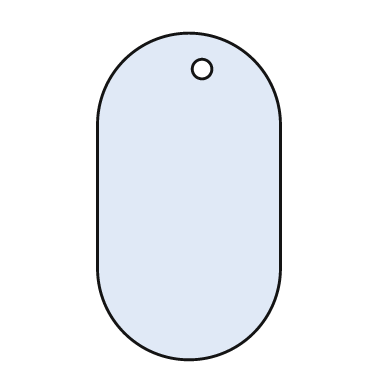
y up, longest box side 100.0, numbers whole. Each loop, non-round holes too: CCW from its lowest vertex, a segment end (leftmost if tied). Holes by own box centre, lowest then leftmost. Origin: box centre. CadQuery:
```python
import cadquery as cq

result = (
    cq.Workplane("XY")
    .moveTo(-28.0, -22.0)
    .threePointArc((0.0, -50.0), (28.0, -22.0))
    .lineTo(28.0, 22.0)
    .threePointArc((0.0, 50.0), (-28.0, 22.0))
    .close()
    .moveTo(4.0, 39.0)
    .circle(3.0)
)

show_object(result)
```